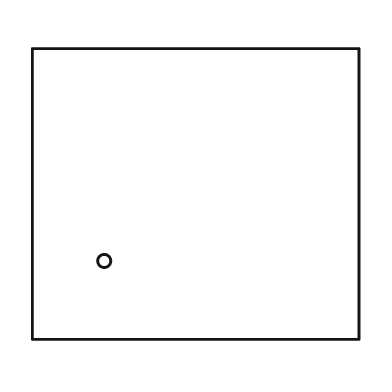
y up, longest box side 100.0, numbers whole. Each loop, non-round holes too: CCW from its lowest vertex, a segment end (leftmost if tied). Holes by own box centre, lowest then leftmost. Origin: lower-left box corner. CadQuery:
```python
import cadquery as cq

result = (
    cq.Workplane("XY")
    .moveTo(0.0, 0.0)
    .lineTo(100.0, 0.0)
    .lineTo(100.0, 89.0)
    .lineTo(0.0, 89.0)
    .close()
    .moveTo(22.0, 24.0)
    .circle(2.0)
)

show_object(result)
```